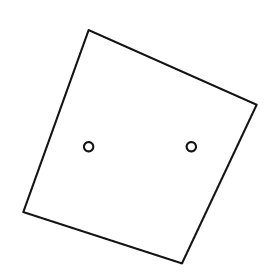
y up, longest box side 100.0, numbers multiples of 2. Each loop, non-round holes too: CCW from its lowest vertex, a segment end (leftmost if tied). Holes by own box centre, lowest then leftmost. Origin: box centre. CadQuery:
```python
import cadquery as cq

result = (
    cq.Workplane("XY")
    .moveTo(18.0, -50.0)
    .lineTo(50.0, 18.0)
    .lineTo(-22.0, 50.0)
    .lineTo(-50.0, -28.0)
    .close()
    .moveTo(-22.0, 0.0)
    .circle(2.0)
    .moveTo(22.0, 0.0)
    .circle(2.0)
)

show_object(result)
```